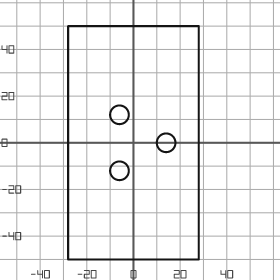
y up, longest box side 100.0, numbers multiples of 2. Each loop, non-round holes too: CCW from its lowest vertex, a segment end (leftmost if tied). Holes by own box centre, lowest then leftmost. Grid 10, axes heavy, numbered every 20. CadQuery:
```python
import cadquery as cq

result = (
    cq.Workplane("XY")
    .moveTo(-28.0, -50.0)
    .lineTo(28.0, -50.0)
    .lineTo(28.0, 50.0)
    .lineTo(-28.0, 50.0)
    .close()
    .moveTo(-6.0, -12.0)
    .circle(4.0)
    .moveTo(14.0, 0.0)
    .circle(4.0)
    .moveTo(-6.0, 12.0)
    .circle(4.0)
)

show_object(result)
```